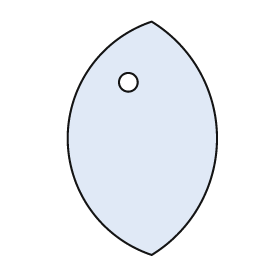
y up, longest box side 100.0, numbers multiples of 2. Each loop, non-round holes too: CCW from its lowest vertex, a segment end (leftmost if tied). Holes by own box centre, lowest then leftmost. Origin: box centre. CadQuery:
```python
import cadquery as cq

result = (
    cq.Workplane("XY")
    .moveTo(4.0, -50.0)
    .threePointArc((32.0, 0.0), (4.0, 50.0))
    .threePointArc((-32.0, 0.0), (4.0, -50.0))
    .close()
    .moveTo(-6.0, 24.0)
    .circle(4.0)
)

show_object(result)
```